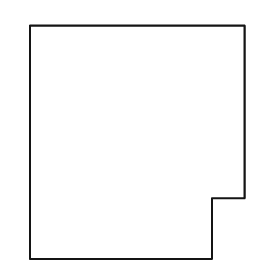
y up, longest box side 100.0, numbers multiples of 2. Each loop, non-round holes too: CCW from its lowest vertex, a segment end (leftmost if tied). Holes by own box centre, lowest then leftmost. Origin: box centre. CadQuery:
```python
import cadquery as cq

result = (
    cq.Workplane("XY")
    .moveTo(-46.0, -50.0)
    .lineTo(32.0, -50.0)
    .lineTo(32.0, -24.0)
    .lineTo(46.0, -24.0)
    .lineTo(46.0, 50.0)
    .lineTo(-46.0, 50.0)
    .close()
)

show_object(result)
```